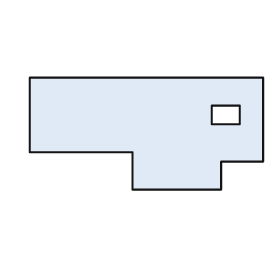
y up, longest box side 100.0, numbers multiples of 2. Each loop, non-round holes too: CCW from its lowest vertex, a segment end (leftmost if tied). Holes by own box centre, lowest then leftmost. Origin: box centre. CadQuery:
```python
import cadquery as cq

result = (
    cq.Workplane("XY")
    .moveTo(-6.0, -24.0)
    .lineTo(32.0, -24.0)
    .lineTo(32.0, -12.0)
    .lineTo(50.0, -12.0)
    .lineTo(50.0, 24.0)
    .lineTo(-50.0, 24.0)
    .lineTo(-50.0, -8.0)
    .lineTo(-6.0, -8.0)
    .close()
    .moveTo(28.0, 4.0)
    .lineTo(40.0, 4.0)
    .lineTo(40.0, 12.0)
    .lineTo(28.0, 12.0)
    .close()
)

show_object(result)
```